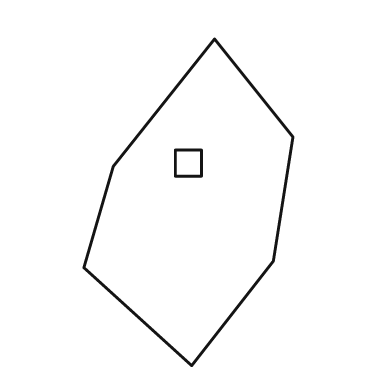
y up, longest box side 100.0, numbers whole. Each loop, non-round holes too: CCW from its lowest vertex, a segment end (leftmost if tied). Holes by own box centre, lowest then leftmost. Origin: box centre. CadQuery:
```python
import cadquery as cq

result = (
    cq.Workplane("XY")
    .moveTo(1.0, -50.0)
    .lineTo(26.0, -18.0)
    .lineTo(32.0, 20.0)
    .lineTo(8.0, 50.0)
    .lineTo(-23.0, 11.0)
    .lineTo(-32.0, -20.0)
    .close()
    .moveTo(-4.0, 8.0)
    .lineTo(4.0, 8.0)
    .lineTo(4.0, 16.0)
    .lineTo(-4.0, 16.0)
    .close()
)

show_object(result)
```